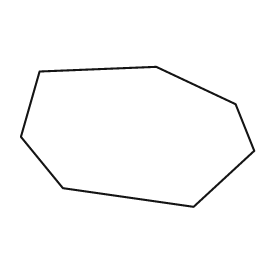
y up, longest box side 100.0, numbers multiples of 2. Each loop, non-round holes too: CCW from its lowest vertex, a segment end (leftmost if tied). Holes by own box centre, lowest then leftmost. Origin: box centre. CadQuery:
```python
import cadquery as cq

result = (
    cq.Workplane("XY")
    .moveTo(24.0, -30.0)
    .lineTo(50.0, -6.0)
    .lineTo(42.0, 14.0)
    .lineTo(8.0, 30.0)
    .lineTo(-42.0, 28.0)
    .lineTo(-50.0, 0.0)
    .lineTo(-32.0, -22.0)
    .close()
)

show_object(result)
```